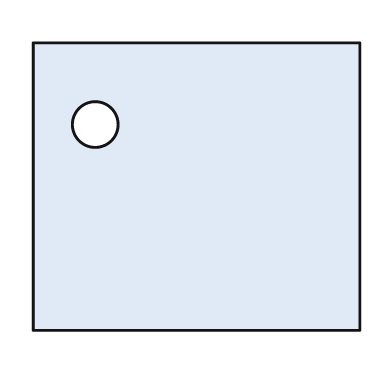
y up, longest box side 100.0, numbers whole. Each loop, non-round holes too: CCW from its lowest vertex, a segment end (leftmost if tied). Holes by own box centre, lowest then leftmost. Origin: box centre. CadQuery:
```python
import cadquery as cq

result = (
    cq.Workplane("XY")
    .moveTo(-50.0, -44.0)
    .lineTo(50.0, -44.0)
    .lineTo(50.0, 44.0)
    .lineTo(-50.0, 44.0)
    .close()
    .moveTo(-31.0, 19.0)
    .circle(7.0)
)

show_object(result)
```